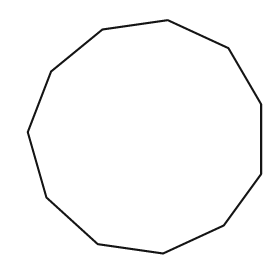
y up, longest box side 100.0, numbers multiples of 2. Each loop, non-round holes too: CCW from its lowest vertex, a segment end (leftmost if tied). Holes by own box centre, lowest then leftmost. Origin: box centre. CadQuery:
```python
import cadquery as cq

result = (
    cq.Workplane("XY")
    .moveTo(8.0, -50.0)
    .lineTo(34.0, -38.0)
    .lineTo(50.0, -16.0)
    .lineTo(50.0, 14.0)
    .lineTo(36.0, 38.0)
    .lineTo(10.0, 50.0)
    .lineTo(-18.0, 46.0)
    .lineTo(-40.0, 28.0)
    .lineTo(-50.0, 2.0)
    .lineTo(-42.0, -26.0)
    .lineTo(-20.0, -46.0)
    .close()
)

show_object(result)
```